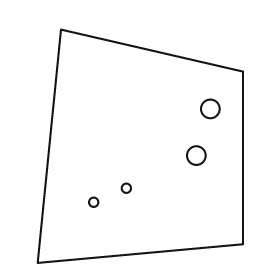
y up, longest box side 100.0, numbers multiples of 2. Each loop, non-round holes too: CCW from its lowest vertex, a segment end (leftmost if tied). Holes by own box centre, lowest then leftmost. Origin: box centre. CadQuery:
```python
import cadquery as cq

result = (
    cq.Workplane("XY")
    .moveTo(-44.0, -50.0)
    .lineTo(44.0, -42.0)
    .lineTo(44.0, 32.0)
    .lineTo(-34.0, 50.0)
    .close()
    .moveTo(-20.0, -24.0)
    .circle(2.0)
    .moveTo(-6.0, -18.0)
    .circle(2.0)
    .moveTo(24.0, -4.0)
    .circle(4.0)
    .moveTo(30.0, 16.0)
    .circle(4.0)
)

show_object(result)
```